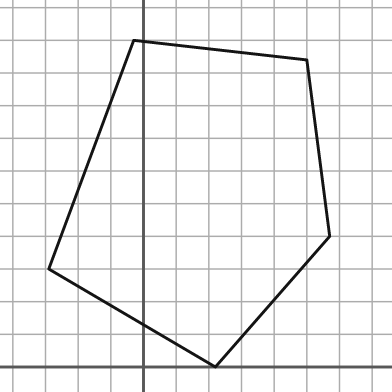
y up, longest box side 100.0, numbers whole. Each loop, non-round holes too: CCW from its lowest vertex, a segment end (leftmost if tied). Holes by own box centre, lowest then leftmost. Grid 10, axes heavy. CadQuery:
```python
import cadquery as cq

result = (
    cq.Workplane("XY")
    .moveTo(22.0, 0.0)
    .lineTo(57.0, 40.0)
    .lineTo(50.0, 94.0)
    .lineTo(-3.0, 100.0)
    .lineTo(-29.0, 30.0)
    .close()
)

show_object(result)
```